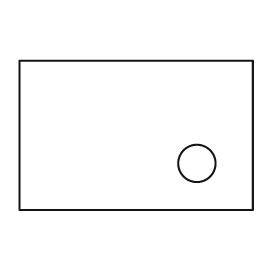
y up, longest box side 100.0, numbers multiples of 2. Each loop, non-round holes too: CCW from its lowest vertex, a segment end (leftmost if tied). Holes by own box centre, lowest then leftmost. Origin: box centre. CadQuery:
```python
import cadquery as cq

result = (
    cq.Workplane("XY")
    .moveTo(-50.0, -32.0)
    .lineTo(50.0, -32.0)
    .lineTo(50.0, 32.0)
    .lineTo(-50.0, 32.0)
    .close()
    .moveTo(26.0, -12.0)
    .circle(8.0)
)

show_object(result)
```